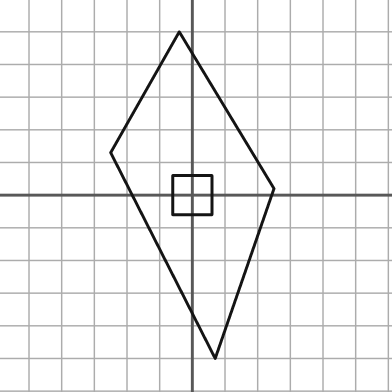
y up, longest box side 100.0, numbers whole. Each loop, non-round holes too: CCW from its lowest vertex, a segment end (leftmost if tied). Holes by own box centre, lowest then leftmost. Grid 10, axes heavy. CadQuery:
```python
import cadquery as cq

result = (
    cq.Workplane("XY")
    .moveTo(7.0, -50.0)
    .lineTo(25.0, 2.0)
    .lineTo(-4.0, 50.0)
    .lineTo(-25.0, 13.0)
    .close()
    .moveTo(-6.0, -6.0)
    .lineTo(6.0, -6.0)
    .lineTo(6.0, 6.0)
    .lineTo(-6.0, 6.0)
    .close()
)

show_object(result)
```